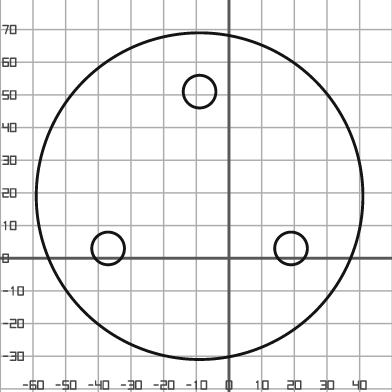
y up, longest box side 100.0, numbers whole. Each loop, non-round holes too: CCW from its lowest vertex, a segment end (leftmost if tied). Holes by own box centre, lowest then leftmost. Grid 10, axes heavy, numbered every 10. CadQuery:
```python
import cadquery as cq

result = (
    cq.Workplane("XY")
    .moveTo(-9.0, 19.0)
    .circle(50.0)
    .moveTo(-37.0, 3.0)
    .circle(5.0)
    .moveTo(19.0, 3.0)
    .circle(5.0)
    .moveTo(-9.0, 51.0)
    .circle(5.0)
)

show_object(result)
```